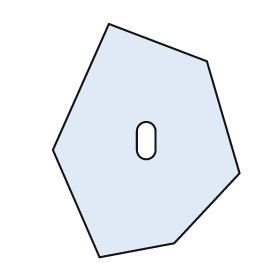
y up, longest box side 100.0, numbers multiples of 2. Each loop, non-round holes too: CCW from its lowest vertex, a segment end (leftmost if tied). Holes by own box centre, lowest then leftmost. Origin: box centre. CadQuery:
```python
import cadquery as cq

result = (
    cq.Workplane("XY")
    .moveTo(-20.0, -50.0)
    .lineTo(12.0, -44.0)
    .lineTo(40.0, -14.0)
    .lineTo(26.0, 34.0)
    .lineTo(-16.0, 50.0)
    .lineTo(-40.0, -4.0)
    .close()
    .moveTo(-4.0, -4.0)
    .threePointArc((0.0, -8.0), (4.0, -4.0))
    .lineTo(4.0, 4.0)
    .threePointArc((0.0, 8.0), (-4.0, 4.0))
    .close()
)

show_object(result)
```